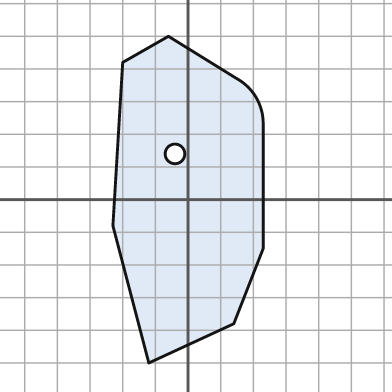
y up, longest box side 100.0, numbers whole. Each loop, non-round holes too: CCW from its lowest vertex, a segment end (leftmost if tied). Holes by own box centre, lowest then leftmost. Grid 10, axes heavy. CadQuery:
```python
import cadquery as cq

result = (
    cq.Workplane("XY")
    .moveTo(-12.0, -50.0)
    .lineTo(14.0, -38.0)
    .lineTo(23.0, -15.0)
    .lineTo(23.0, 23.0)
    .threePointArc((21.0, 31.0), (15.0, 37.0))
    .lineTo(-6.0, 50.0)
    .lineTo(-20.0, 42.0)
    .lineTo(-23.0, -8.0)
    .close()
    .moveTo(-4.0, 14.0)
    .circle(3.0)
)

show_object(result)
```